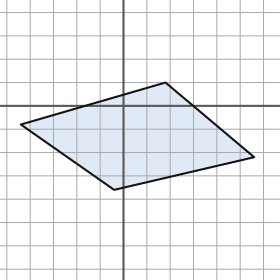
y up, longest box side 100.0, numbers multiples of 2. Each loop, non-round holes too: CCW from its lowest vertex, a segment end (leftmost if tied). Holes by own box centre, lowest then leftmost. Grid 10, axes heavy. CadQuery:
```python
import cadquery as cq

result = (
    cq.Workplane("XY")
    .moveTo(-4.0, -36.0)
    .lineTo(56.0, -22.0)
    .lineTo(18.0, 10.0)
    .lineTo(-44.0, -8.0)
    .close()
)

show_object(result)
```